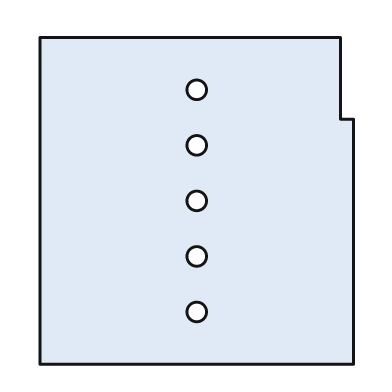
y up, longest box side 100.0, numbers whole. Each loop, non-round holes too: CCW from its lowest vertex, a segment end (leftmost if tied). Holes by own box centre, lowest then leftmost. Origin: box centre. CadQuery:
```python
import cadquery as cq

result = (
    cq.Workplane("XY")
    .moveTo(-48.0, -50.0)
    .lineTo(48.0, -50.0)
    .lineTo(48.0, 25.0)
    .lineTo(44.0, 25.0)
    .lineTo(44.0, 50.0)
    .lineTo(-48.0, 50.0)
    .close()
    .moveTo(0.0, -34.0)
    .circle(3.0)
    .moveTo(0.0, -17.0)
    .circle(3.0)
    .moveTo(0.0, 0.0)
    .circle(3.0)
    .moveTo(0.0, 17.0)
    .circle(3.0)
    .moveTo(0.0, 34.0)
    .circle(3.0)
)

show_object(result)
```